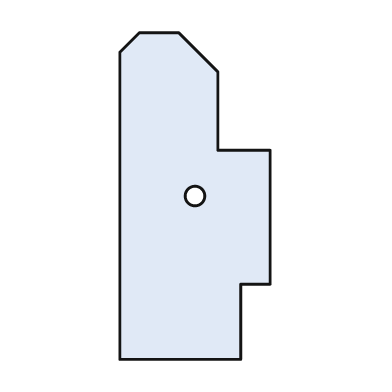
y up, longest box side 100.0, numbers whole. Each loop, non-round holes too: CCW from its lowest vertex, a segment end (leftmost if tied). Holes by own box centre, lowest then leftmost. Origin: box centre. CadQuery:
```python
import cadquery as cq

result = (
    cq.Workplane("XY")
    .moveTo(-23.0, -50.0)
    .lineTo(14.0, -50.0)
    .lineTo(14.0, -27.0)
    .lineTo(23.0, -27.0)
    .lineTo(23.0, 14.0)
    .lineTo(7.0, 14.0)
    .lineTo(7.0, 38.0)
    .lineTo(-5.0, 50.0)
    .lineTo(-17.0, 50.0)
    .lineTo(-23.0, 44.0)
    .close()
    .moveTo(0.0, 0.0)
    .circle(3.0)
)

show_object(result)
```